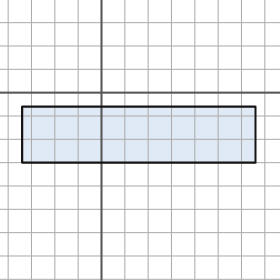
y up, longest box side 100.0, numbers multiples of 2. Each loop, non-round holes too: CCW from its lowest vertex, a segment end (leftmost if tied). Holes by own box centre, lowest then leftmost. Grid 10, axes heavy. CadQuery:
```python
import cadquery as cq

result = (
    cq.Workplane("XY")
    .moveTo(-34.0, -30.0)
    .lineTo(66.0, -30.0)
    .lineTo(66.0, -6.0)
    .lineTo(-34.0, -6.0)
    .close()
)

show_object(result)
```